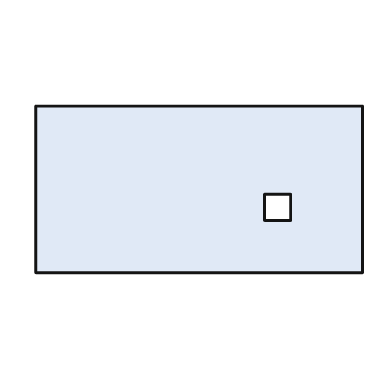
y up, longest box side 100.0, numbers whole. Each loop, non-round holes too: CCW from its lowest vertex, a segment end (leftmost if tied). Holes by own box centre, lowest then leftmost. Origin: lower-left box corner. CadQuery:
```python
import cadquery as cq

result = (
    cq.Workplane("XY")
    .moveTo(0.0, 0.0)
    .lineTo(100.0, 0.0)
    .lineTo(100.0, 51.0)
    .lineTo(0.0, 51.0)
    .close()
    .moveTo(70.0, 16.0)
    .lineTo(78.0, 16.0)
    .lineTo(78.0, 24.0)
    .lineTo(70.0, 24.0)
    .close()
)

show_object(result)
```